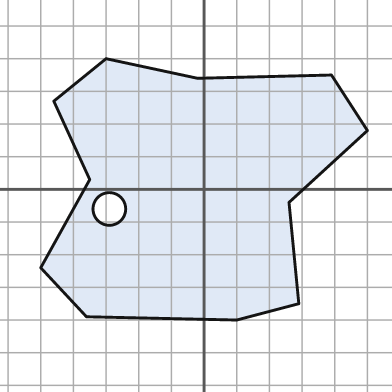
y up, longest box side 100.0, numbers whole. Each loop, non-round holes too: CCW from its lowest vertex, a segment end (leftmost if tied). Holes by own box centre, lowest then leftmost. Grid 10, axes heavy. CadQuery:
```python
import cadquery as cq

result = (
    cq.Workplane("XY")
    .moveTo(10.0, -40.0)
    .lineTo(29.0, -35.0)
    .lineTo(26.0, -4.0)
    .lineTo(50.0, 18.0)
    .lineTo(39.0, 35.0)
    .lineTo(-2.0, 34.0)
    .lineTo(-30.0, 40.0)
    .lineTo(-46.0, 27.0)
    .lineTo(-35.0, 3.0)
    .lineTo(-50.0, -24.0)
    .lineTo(-36.0, -39.0)
    .close()
    .moveTo(-29.0, -6.0)
    .circle(5.0)
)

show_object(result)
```